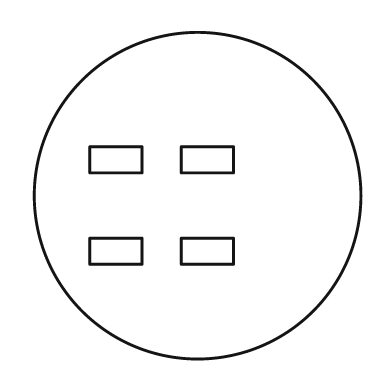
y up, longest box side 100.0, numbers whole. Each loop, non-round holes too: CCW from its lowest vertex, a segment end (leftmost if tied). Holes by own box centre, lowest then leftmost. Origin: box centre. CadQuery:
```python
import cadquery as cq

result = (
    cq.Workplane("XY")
    .moveTo(0.0, 0.0)
    .circle(50.0)
    .moveTo(-33.0, -21.0)
    .lineTo(-17.0, -21.0)
    .lineTo(-17.0, -13.0)
    .lineTo(-33.0, -13.0)
    .close()
    .moveTo(-5.0, -21.0)
    .lineTo(11.0, -21.0)
    .lineTo(11.0, -13.0)
    .lineTo(-5.0, -13.0)
    .close()
    .moveTo(-33.0, 7.0)
    .lineTo(-17.0, 7.0)
    .lineTo(-17.0, 15.0)
    .lineTo(-33.0, 15.0)
    .close()
    .moveTo(-5.0, 7.0)
    .lineTo(11.0, 7.0)
    .lineTo(11.0, 15.0)
    .lineTo(-5.0, 15.0)
    .close()
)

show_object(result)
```